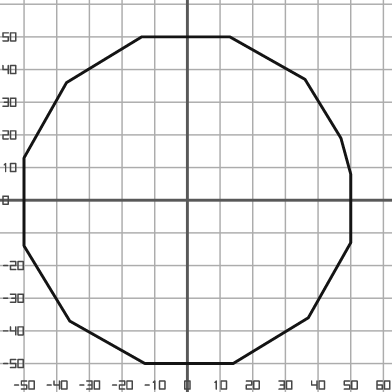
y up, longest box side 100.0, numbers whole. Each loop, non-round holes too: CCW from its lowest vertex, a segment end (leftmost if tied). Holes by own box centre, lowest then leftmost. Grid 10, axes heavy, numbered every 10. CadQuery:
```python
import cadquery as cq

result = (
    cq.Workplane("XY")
    .moveTo(-13.0, -50.0)
    .lineTo(14.0, -50.0)
    .lineTo(37.0, -36.0)
    .lineTo(50.0, -13.0)
    .lineTo(50.0, 8.0)
    .lineTo(47.0, 19.0)
    .lineTo(36.0, 37.0)
    .lineTo(13.0, 50.0)
    .lineTo(-14.0, 50.0)
    .lineTo(-37.0, 36.0)
    .lineTo(-50.0, 13.0)
    .lineTo(-50.0, -14.0)
    .lineTo(-36.0, -37.0)
    .close()
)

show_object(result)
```